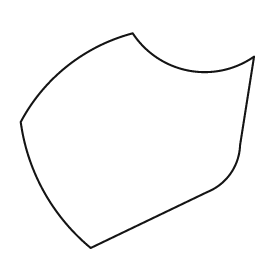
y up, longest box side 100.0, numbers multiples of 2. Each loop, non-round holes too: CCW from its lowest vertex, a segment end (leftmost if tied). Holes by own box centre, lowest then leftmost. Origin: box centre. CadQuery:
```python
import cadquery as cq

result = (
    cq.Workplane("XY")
    .moveTo(-20.0, -46.0)
    .lineTo(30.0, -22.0)
    .threePointArc((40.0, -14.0), (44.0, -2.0))
    .lineTo(50.0, 36.0)
    .threePointArc((22.0, 30.0), (-2.0, 46.0))
    .threePointArc((-30.0, 32.0), (-50.0, 8.0))
    .threePointArc((-40.0, -22.0), (-20.0, -46.0))
    .close()
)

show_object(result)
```